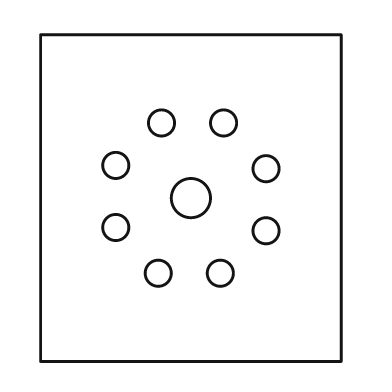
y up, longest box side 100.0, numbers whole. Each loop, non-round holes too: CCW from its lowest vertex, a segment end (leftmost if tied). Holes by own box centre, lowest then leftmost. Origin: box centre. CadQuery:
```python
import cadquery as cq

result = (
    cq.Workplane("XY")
    .moveTo(-46.0, -50.0)
    .lineTo(46.0, -50.0)
    .lineTo(46.0, 50.0)
    .lineTo(-46.0, 50.0)
    .close()
    .moveTo(-10.0, -23.0)
    .circle(4.0)
    .moveTo(9.0, -23.0)
    .circle(4.0)
    .moveTo(23.0, -10.0)
    .circle(4.0)
    .moveTo(-23.0, -9.0)
    .circle(4.0)
    .moveTo(0.0, 0.0)
    .circle(6.0)
    .moveTo(23.0, 9.0)
    .circle(4.0)
    .moveTo(-23.0, 10.0)
    .circle(4.0)
    .moveTo(-9.0, 23.0)
    .circle(4.0)
    .moveTo(10.0, 23.0)
    .circle(4.0)
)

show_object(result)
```